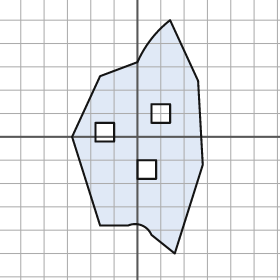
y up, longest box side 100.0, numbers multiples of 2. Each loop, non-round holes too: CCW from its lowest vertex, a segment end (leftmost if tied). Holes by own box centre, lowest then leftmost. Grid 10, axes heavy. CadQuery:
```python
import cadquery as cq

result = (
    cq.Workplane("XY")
    .moveTo(16.0, -50.0)
    .lineTo(28.0, -12.0)
    .lineTo(26.0, 24.0)
    .lineTo(14.0, 50.0)
    .threePointArc((6.0, 42.0), (0.0, 32.0))
    .lineTo(-16.0, 26.0)
    .lineTo(-28.0, 0.0)
    .lineTo(-16.0, -38.0)
    .lineTo(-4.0, -38.0)
    .threePointArc((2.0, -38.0), (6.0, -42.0))
    .close()
    .moveTo(0.0, -18.0)
    .lineTo(8.0, -18.0)
    .lineTo(8.0, -10.0)
    .lineTo(0.0, -10.0)
    .close()
    .moveTo(-18.0, -2.0)
    .lineTo(-10.0, -2.0)
    .lineTo(-10.0, 6.0)
    .lineTo(-18.0, 6.0)
    .close()
    .moveTo(6.0, 6.0)
    .lineTo(14.0, 6.0)
    .lineTo(14.0, 14.0)
    .lineTo(6.0, 14.0)
    .close()
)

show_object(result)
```